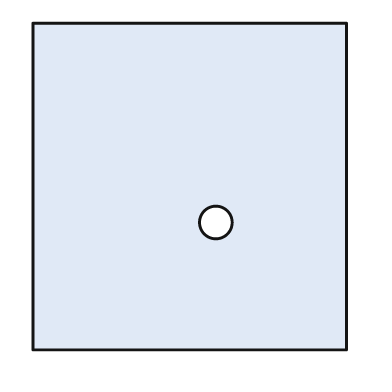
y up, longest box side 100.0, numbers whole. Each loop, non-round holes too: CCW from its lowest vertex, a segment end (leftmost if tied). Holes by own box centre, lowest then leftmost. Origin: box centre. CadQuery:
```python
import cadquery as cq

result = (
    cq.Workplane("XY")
    .moveTo(-48.0, -50.0)
    .lineTo(48.0, -50.0)
    .lineTo(48.0, 50.0)
    .lineTo(-48.0, 50.0)
    .close()
    .moveTo(8.0, -11.0)
    .circle(5.0)
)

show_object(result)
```